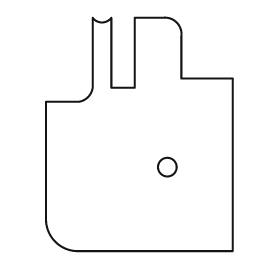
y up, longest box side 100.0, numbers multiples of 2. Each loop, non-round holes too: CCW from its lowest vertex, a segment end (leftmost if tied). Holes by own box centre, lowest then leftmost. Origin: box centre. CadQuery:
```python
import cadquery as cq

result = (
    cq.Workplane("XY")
    .moveTo(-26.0, -50.0)
    .lineTo(40.0, -50.0)
    .lineTo(40.0, 24.0)
    .lineTo(18.0, 24.0)
    .lineTo(18.0, 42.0)
    .threePointArc((16.0, 48.0), (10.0, 50.0))
    .lineTo(-2.0, 50.0)
    .lineTo(-2.0, 20.0)
    .lineTo(-12.0, 20.0)
    .lineTo(-12.0, 50.0)
    .threePointArc((-16.0, 48.0), (-20.0, 50.0))
    .lineTo(-20.0, 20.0)
    .threePointArc((-22.0, 16.0), (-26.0, 14.0))
    .lineTo(-40.0, 14.0)
    .lineTo(-40.0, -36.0)
    .threePointArc((-36.0, -46.0), (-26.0, -50.0))
    .close()
    .moveTo(12.0, -14.0)
    .circle(4.0)
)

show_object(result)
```